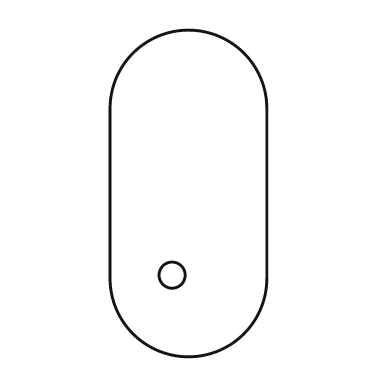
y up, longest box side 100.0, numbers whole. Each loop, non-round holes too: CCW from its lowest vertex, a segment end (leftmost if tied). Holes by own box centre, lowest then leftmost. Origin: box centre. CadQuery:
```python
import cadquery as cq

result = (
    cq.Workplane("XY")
    .moveTo(-24.0, -26.0)
    .threePointArc((0.0, -50.0), (24.0, -26.0))
    .lineTo(24.0, 26.0)
    .threePointArc((0.0, 50.0), (-24.0, 26.0))
    .close()
    .moveTo(-5.0, -25.0)
    .circle(4.0)
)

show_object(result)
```